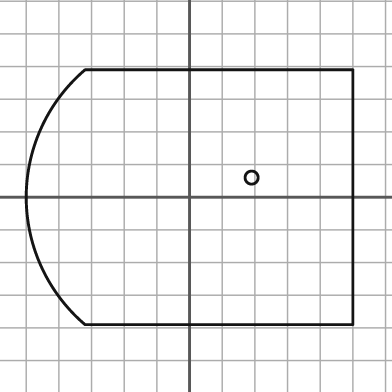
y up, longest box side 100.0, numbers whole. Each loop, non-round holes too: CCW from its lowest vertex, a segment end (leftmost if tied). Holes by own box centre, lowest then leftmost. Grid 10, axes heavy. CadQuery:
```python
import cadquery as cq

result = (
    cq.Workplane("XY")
    .moveTo(-32.0, -39.0)
    .lineTo(50.0, -39.0)
    .lineTo(50.0, 39.0)
    .lineTo(-32.0, 39.0)
    .threePointArc((-50.0, 0.0), (-32.0, -39.0))
    .close()
    .moveTo(19.0, 6.0)
    .circle(2.0)
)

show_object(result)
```